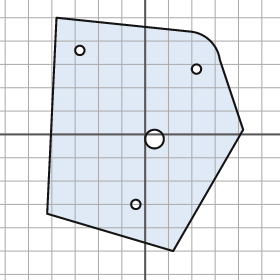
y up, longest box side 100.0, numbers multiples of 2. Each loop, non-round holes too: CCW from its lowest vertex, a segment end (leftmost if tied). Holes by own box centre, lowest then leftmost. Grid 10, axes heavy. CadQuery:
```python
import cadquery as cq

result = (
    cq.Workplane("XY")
    .moveTo(12.0, -50.0)
    .lineTo(42.0, 2.0)
    .lineTo(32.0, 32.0)
    .threePointArc((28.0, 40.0), (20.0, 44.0))
    .lineTo(-38.0, 50.0)
    .lineTo(-42.0, -34.0)
    .close()
    .moveTo(-4.0, -30.0)
    .circle(2.0)
    .moveTo(4.0, -2.0)
    .circle(4.0)
    .moveTo(22.0, 28.0)
    .circle(2.0)
    .moveTo(-28.0, 36.0)
    .circle(2.0)
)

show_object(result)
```